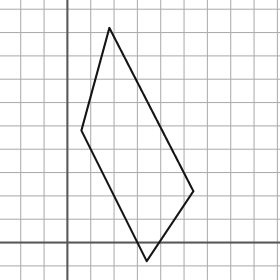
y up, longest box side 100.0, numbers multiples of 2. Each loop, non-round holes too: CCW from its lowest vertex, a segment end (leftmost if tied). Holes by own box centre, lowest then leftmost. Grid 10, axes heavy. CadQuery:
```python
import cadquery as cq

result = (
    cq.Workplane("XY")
    .moveTo(34.0, -8.0)
    .lineTo(54.0, 22.0)
    .lineTo(18.0, 92.0)
    .lineTo(6.0, 48.0)
    .close()
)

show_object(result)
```